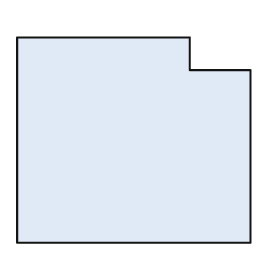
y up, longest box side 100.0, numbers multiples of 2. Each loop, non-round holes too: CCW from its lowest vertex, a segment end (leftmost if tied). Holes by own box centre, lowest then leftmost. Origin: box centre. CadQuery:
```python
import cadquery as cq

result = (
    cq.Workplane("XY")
    .moveTo(-50.0, -44.0)
    .lineTo(50.0, -44.0)
    .lineTo(50.0, 30.0)
    .lineTo(24.0, 30.0)
    .lineTo(24.0, 44.0)
    .lineTo(-50.0, 44.0)
    .close()
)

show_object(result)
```